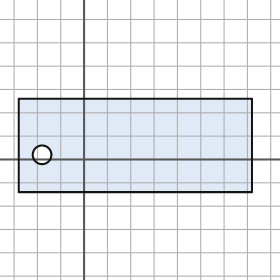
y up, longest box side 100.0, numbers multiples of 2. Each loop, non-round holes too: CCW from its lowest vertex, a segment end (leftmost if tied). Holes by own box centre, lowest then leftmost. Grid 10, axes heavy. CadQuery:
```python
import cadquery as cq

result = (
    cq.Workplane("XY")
    .moveTo(-28.0, -14.0)
    .lineTo(72.0, -14.0)
    .lineTo(72.0, 26.0)
    .lineTo(-28.0, 26.0)
    .close()
    .moveTo(-18.0, 2.0)
    .circle(4.0)
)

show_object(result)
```